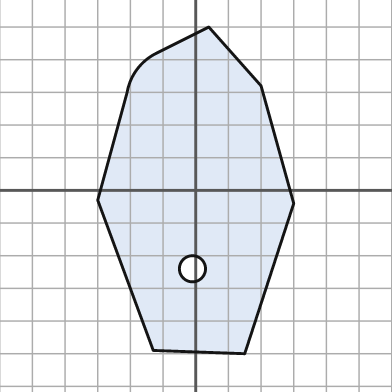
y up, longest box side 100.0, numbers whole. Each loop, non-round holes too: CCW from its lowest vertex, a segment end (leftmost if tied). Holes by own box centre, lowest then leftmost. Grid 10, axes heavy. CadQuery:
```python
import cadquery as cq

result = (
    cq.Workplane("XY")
    .moveTo(15.0, -50.0)
    .lineTo(30.0, -4.0)
    .lineTo(20.0, 32.0)
    .lineTo(4.0, 50.0)
    .lineTo(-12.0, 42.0)
    .threePointArc((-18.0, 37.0), (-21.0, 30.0))
    .lineTo(-30.0, -3.0)
    .lineTo(-13.0, -49.0)
    .close()
    .moveTo(-1.0, -24.0)
    .circle(4.0)
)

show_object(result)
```